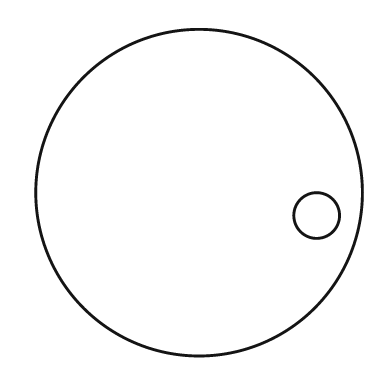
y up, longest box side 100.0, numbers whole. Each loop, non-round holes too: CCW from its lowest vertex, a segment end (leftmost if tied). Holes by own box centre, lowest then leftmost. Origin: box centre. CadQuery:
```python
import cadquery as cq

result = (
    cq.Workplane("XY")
    .moveTo(0.0, 0.0)
    .circle(50.0)
    .moveTo(36.0, -7.0)
    .circle(7.0)
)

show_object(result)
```